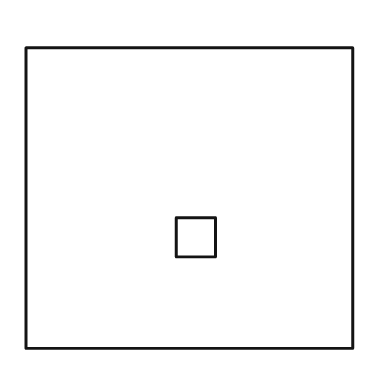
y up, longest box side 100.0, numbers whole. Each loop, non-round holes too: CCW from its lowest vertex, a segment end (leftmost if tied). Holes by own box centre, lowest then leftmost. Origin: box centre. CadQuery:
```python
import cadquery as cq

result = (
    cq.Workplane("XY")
    .moveTo(-50.0, -46.0)
    .lineTo(50.0, -46.0)
    .lineTo(50.0, 46.0)
    .lineTo(-50.0, 46.0)
    .close()
    .moveTo(-4.0, -18.0)
    .lineTo(8.0, -18.0)
    .lineTo(8.0, -6.0)
    .lineTo(-4.0, -6.0)
    .close()
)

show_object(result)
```